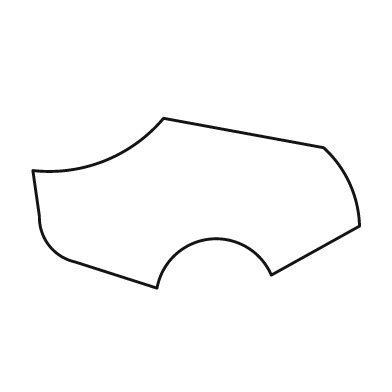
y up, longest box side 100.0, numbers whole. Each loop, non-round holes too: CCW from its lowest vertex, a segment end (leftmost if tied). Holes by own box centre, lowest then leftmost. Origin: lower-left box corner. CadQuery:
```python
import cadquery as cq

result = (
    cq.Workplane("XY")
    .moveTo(38.0, 0.0)
    .threePointArc((54.0, 15.0), (73.0, 4.0))
    .lineTo(100.0, 19.0)
    .threePointArc((97.0, 32.0), (89.0, 43.0))
    .lineTo(40.0, 52.0)
    .threePointArc((22.0, 39.0), (0.0, 36.0))
    .lineTo(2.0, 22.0)
    .threePointArc((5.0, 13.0), (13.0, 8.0))
    .close()
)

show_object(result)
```